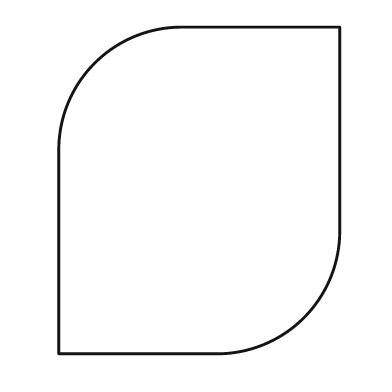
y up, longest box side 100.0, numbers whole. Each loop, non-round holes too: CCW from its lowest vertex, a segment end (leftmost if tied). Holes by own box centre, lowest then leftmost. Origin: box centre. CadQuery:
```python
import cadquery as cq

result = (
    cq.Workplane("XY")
    .moveTo(-43.0, -50.0)
    .lineTo(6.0, -50.0)
    .threePointArc((32.0, -39.0), (43.0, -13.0))
    .lineTo(43.0, 50.0)
    .lineTo(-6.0, 50.0)
    .threePointArc((-32.0, 39.0), (-43.0, 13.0))
    .close()
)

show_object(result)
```